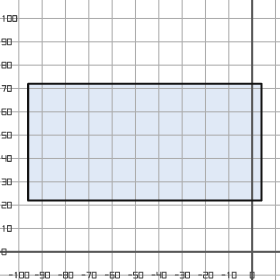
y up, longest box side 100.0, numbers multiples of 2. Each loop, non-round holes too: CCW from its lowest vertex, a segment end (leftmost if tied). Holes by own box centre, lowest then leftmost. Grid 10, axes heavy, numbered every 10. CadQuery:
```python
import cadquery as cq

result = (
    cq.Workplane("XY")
    .moveTo(-96.0, 22.0)
    .lineTo(4.0, 22.0)
    .lineTo(4.0, 72.0)
    .lineTo(-96.0, 72.0)
    .close()
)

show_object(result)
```